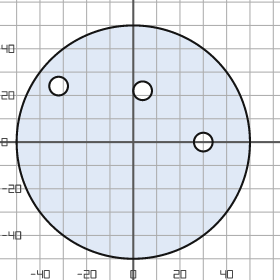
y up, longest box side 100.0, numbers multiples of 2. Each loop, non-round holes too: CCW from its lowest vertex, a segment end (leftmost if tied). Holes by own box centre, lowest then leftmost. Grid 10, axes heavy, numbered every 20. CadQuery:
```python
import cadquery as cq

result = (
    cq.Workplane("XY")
    .moveTo(0.0, 0.0)
    .circle(50.0)
    .moveTo(30.0, 0.0)
    .circle(4.0)
    .moveTo(4.0, 22.0)
    .circle(4.0)
    .moveTo(-32.0, 24.0)
    .circle(4.0)
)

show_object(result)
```